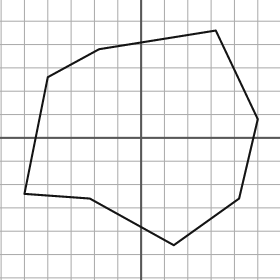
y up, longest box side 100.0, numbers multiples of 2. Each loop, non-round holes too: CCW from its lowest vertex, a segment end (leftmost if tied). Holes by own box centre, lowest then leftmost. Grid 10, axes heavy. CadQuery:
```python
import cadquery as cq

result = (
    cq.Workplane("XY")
    .moveTo(14.0, -46.0)
    .lineTo(42.0, -26.0)
    .lineTo(50.0, 8.0)
    .lineTo(32.0, 46.0)
    .lineTo(-18.0, 38.0)
    .lineTo(-40.0, 26.0)
    .lineTo(-50.0, -24.0)
    .lineTo(-22.0, -26.0)
    .close()
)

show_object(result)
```